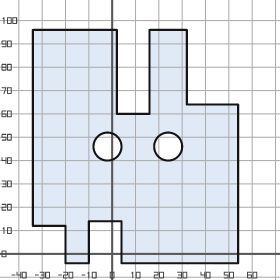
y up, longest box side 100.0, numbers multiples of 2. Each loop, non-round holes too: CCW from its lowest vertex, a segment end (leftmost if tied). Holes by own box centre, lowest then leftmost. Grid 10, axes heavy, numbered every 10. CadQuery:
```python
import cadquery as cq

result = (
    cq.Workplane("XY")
    .moveTo(-20.0, -4.0)
    .lineTo(-10.0, -4.0)
    .lineTo(-10.0, 14.0)
    .lineTo(4.0, 14.0)
    .lineTo(4.0, -4.0)
    .lineTo(54.0, -4.0)
    .lineTo(54.0, 64.0)
    .lineTo(32.0, 64.0)
    .lineTo(32.0, 96.0)
    .lineTo(16.0, 96.0)
    .lineTo(16.0, 60.0)
    .lineTo(2.0, 60.0)
    .lineTo(2.0, 96.0)
    .lineTo(-34.0, 96.0)
    .lineTo(-34.0, 12.0)
    .lineTo(-20.0, 12.0)
    .close()
    .moveTo(-2.0, 46.0)
    .circle(6.0)
    .moveTo(24.0, 46.0)
    .circle(6.0)
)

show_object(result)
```